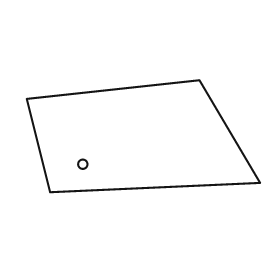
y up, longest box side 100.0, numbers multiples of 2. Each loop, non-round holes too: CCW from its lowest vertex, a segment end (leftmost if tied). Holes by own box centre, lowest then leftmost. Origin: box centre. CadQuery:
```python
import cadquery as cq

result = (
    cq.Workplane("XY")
    .moveTo(-40.0, -24.0)
    .lineTo(50.0, -20.0)
    .lineTo(24.0, 24.0)
    .lineTo(-50.0, 16.0)
    .close()
    .moveTo(-26.0, -12.0)
    .circle(2.0)
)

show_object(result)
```